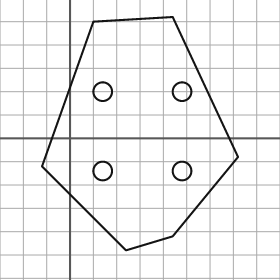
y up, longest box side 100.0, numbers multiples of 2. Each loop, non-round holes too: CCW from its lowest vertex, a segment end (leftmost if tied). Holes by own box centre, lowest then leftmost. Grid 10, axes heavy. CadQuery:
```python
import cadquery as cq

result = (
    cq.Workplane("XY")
    .moveTo(24.0, -48.0)
    .lineTo(44.0, -42.0)
    .lineTo(72.0, -8.0)
    .lineTo(44.0, 52.0)
    .lineTo(10.0, 50.0)
    .lineTo(-12.0, -12.0)
    .close()
    .moveTo(14.0, -14.0)
    .circle(4.0)
    .moveTo(48.0, -14.0)
    .circle(4.0)
    .moveTo(14.0, 20.0)
    .circle(4.0)
    .moveTo(48.0, 20.0)
    .circle(4.0)
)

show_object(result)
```